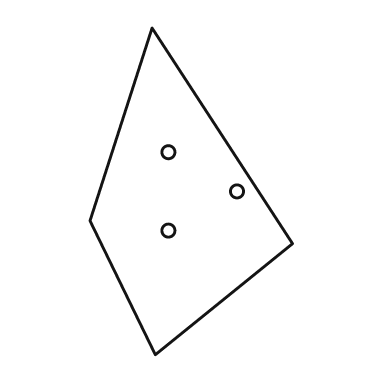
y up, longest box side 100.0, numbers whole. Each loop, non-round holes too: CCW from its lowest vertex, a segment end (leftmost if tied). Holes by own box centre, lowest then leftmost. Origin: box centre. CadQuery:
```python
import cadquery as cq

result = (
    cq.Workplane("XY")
    .moveTo(-11.0, -50.0)
    .lineTo(31.0, -16.0)
    .lineTo(-12.0, 50.0)
    .lineTo(-31.0, -9.0)
    .close()
    .moveTo(-7.0, -12.0)
    .circle(2.0)
    .moveTo(14.0, 0.0)
    .circle(2.0)
    .moveTo(-7.0, 12.0)
    .circle(2.0)
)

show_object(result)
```